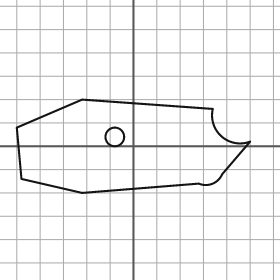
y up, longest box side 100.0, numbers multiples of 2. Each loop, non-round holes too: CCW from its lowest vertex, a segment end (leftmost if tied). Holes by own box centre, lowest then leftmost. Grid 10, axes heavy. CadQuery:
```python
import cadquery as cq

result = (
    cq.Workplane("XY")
    .moveTo(-22.0, -20.0)
    .lineTo(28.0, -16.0)
    .threePointArc((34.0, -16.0), (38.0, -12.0))
    .lineTo(50.0, 2.0)
    .threePointArc((38.0, 4.0), (34.0, 16.0))
    .lineTo(-22.0, 20.0)
    .lineTo(-50.0, 8.0)
    .lineTo(-48.0, -14.0)
    .close()
    .moveTo(-8.0, 4.0)
    .circle(4.0)
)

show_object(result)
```